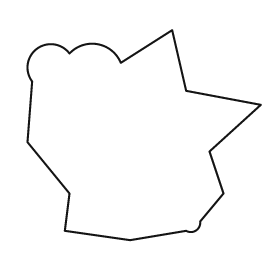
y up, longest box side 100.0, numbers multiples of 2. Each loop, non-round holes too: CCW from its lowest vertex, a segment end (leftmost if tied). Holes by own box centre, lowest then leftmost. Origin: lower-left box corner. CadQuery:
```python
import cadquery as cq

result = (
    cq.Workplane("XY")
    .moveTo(44.0, 0.0)
    .lineTo(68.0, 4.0)
    .threePointArc((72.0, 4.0), (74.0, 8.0))
    .lineTo(84.0, 20.0)
    .lineTo(78.0, 38.0)
    .lineTo(100.0, 58.0)
    .lineTo(68.0, 64.0)
    .lineTo(62.0, 90.0)
    .lineTo(40.0, 76.0)
    .threePointArc((30.0, 84.0), (18.0, 80.0))
    .threePointArc((4.0, 82.0), (2.0, 68.0))
    .lineTo(0.0, 42.0)
    .lineTo(18.0, 20.0)
    .lineTo(16.0, 4.0)
    .close()
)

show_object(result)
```